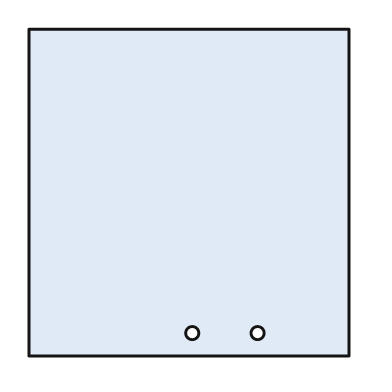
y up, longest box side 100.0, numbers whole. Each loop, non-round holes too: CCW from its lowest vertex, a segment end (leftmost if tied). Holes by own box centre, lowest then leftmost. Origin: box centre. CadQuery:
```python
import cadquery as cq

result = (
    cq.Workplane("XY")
    .moveTo(-49.0, -50.0)
    .lineTo(49.0, -50.0)
    .lineTo(49.0, 50.0)
    .lineTo(-49.0, 50.0)
    .close()
    .moveTo(1.0, -43.0)
    .circle(2.0)
    .moveTo(21.0, -43.0)
    .circle(2.0)
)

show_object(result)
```